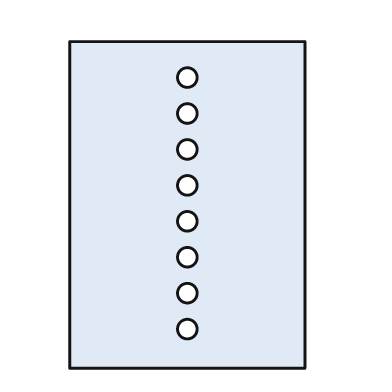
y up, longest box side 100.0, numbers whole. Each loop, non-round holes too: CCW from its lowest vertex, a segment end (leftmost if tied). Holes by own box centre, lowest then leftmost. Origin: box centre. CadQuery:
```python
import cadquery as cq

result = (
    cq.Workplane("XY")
    .moveTo(-36.0, -50.0)
    .lineTo(36.0, -50.0)
    .lineTo(36.0, 50.0)
    .lineTo(-36.0, 50.0)
    .close()
    .moveTo(0.0, -38.0)
    .circle(3.0)
    .moveTo(0.0, -27.0)
    .circle(3.0)
    .moveTo(0.0, -16.0)
    .circle(3.0)
    .moveTo(0.0, -5.0)
    .circle(3.0)
    .moveTo(0.0, 6.0)
    .circle(3.0)
    .moveTo(0.0, 17.0)
    .circle(3.0)
    .moveTo(0.0, 28.0)
    .circle(3.0)
    .moveTo(0.0, 39.0)
    .circle(3.0)
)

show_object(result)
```